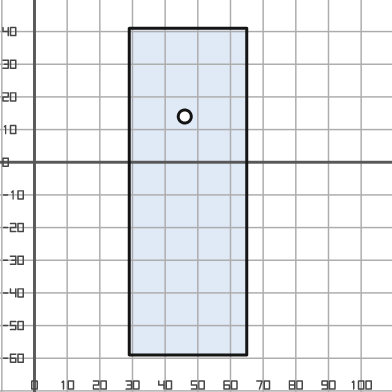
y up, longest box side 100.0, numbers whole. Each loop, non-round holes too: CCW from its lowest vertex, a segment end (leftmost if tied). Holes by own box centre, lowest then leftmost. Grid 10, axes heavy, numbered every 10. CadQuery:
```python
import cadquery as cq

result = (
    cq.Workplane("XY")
    .moveTo(29.0, -59.0)
    .lineTo(65.0, -59.0)
    .lineTo(65.0, 41.0)
    .lineTo(29.0, 41.0)
    .close()
    .moveTo(46.0, 14.0)
    .circle(2.0)
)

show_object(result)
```